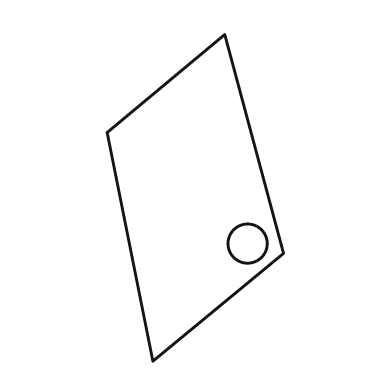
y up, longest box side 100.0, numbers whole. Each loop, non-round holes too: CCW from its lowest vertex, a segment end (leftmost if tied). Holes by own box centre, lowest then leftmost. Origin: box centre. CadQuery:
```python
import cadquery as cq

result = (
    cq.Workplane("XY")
    .moveTo(-13.0, -50.0)
    .lineTo(27.0, -17.0)
    .lineTo(9.0, 50.0)
    .lineTo(-27.0, 20.0)
    .close()
    .moveTo(16.0, -14.0)
    .circle(6.0)
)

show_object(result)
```